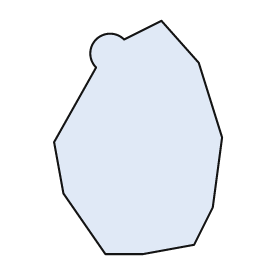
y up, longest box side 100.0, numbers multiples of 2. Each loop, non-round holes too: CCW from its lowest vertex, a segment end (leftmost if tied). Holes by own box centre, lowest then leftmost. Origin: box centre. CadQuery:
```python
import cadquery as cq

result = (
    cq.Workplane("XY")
    .moveTo(-14.0, -50.0)
    .lineTo(2.0, -50.0)
    .lineTo(24.0, -46.0)
    .lineTo(32.0, -30.0)
    .lineTo(36.0, 0.0)
    .lineTo(26.0, 32.0)
    .lineTo(10.0, 50.0)
    .lineTo(-6.0, 42.0)
    .threePointArc((-18.0, 42.0), (-18.0, 30.0))
    .lineTo(-36.0, -2.0)
    .lineTo(-32.0, -24.0)
    .close()
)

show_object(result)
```